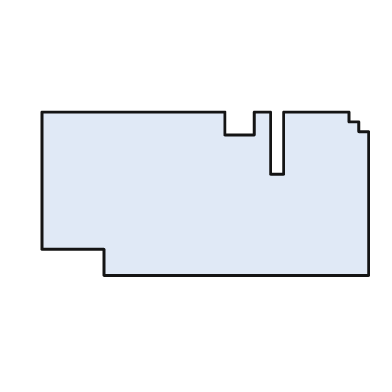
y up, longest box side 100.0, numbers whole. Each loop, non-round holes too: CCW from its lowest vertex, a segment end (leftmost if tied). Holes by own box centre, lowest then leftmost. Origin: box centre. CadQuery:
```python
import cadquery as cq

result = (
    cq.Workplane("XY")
    .moveTo(-31.0, -25.0)
    .lineTo(50.0, -25.0)
    .lineTo(50.0, 19.0)
    .lineTo(47.0, 19.0)
    .lineTo(47.0, 22.0)
    .lineTo(44.0, 22.0)
    .lineTo(44.0, 25.0)
    .lineTo(24.0, 25.0)
    .lineTo(24.0, 6.0)
    .lineTo(20.0, 6.0)
    .lineTo(20.0, 25.0)
    .lineTo(15.0, 25.0)
    .lineTo(15.0, 18.0)
    .lineTo(6.0, 18.0)
    .lineTo(6.0, 25.0)
    .lineTo(-50.0, 25.0)
    .lineTo(-50.0, -17.0)
    .lineTo(-31.0, -17.0)
    .close()
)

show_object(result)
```